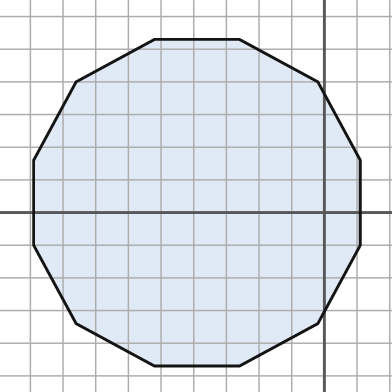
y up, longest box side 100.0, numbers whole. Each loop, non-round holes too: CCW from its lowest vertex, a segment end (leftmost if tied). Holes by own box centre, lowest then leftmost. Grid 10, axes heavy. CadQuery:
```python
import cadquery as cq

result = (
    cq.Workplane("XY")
    .moveTo(-52.0, -47.0)
    .lineTo(-26.0, -47.0)
    .lineTo(-2.0, -34.0)
    .lineTo(11.0, -10.0)
    .lineTo(11.0, 16.0)
    .lineTo(-2.0, 40.0)
    .lineTo(-26.0, 53.0)
    .lineTo(-52.0, 53.0)
    .lineTo(-76.0, 40.0)
    .lineTo(-89.0, 16.0)
    .lineTo(-89.0, -10.0)
    .lineTo(-76.0, -34.0)
    .close()
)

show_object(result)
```